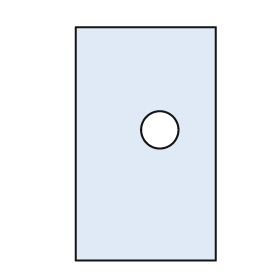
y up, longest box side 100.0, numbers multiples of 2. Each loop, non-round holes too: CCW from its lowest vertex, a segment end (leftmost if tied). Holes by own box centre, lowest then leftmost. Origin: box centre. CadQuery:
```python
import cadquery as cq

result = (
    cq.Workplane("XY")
    .moveTo(-30.0, -50.0)
    .lineTo(30.0, -50.0)
    .lineTo(30.0, 50.0)
    .lineTo(-30.0, 50.0)
    .close()
    .moveTo(6.0, 6.0)
    .circle(8.0)
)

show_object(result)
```